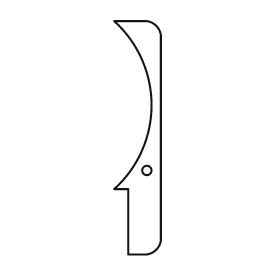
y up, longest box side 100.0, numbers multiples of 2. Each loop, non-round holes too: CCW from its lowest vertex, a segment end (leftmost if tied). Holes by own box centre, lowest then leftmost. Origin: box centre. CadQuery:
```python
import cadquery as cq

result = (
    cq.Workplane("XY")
    .moveTo(-4.0, -50.0)
    .lineTo(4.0, -50.0)
    .threePointArc((8.0, -48.0), (10.0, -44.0))
    .lineTo(10.0, 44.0)
    .threePointArc((8.0, 48.0), (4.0, 50.0))
    .lineTo(-10.0, 50.0)
    .threePointArc((6.0, 14.0), (-10.0, -22.0))
    .lineTo(-4.0, -22.0)
    .close()
    .moveTo(4.0, -14.0)
    .circle(2.0)
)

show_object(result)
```